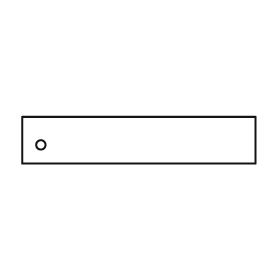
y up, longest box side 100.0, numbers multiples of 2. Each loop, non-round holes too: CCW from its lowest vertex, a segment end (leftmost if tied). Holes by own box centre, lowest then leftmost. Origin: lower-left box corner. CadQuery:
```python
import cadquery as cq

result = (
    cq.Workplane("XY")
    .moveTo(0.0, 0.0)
    .lineTo(100.0, 0.0)
    .lineTo(100.0, 20.0)
    .lineTo(0.0, 20.0)
    .close()
    .moveTo(8.0, 8.0)
    .circle(2.0)
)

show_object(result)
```